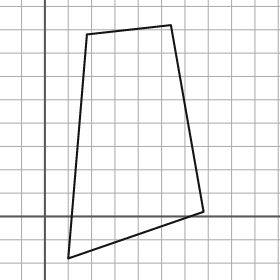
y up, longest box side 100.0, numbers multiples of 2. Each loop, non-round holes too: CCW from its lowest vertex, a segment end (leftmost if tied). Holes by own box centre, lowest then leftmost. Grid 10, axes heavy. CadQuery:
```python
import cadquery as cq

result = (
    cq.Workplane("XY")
    .moveTo(10.0, -18.0)
    .lineTo(68.0, 2.0)
    .lineTo(54.0, 82.0)
    .lineTo(18.0, 78.0)
    .close()
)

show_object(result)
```